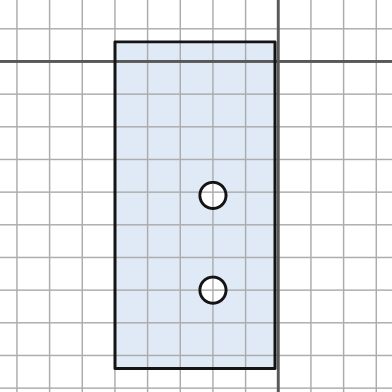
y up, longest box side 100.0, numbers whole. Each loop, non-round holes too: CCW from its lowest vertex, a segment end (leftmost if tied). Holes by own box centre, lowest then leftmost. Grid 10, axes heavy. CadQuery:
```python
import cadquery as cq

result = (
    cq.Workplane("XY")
    .moveTo(-50.0, -94.0)
    .lineTo(-1.0, -94.0)
    .lineTo(-1.0, 6.0)
    .lineTo(-50.0, 6.0)
    .close()
    .moveTo(-20.0, -70.0)
    .circle(4.0)
    .moveTo(-20.0, -41.0)
    .circle(4.0)
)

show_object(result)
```